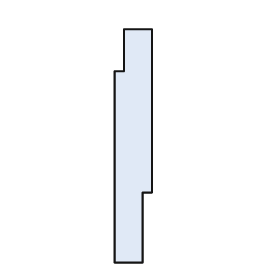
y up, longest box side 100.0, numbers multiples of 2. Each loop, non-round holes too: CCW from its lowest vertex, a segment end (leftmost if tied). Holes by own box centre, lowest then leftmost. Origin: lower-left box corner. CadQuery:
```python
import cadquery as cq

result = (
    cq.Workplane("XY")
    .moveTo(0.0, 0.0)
    .lineTo(12.0, 0.0)
    .lineTo(12.0, 30.0)
    .lineTo(16.0, 30.0)
    .lineTo(16.0, 100.0)
    .lineTo(4.0, 100.0)
    .lineTo(4.0, 82.0)
    .lineTo(0.0, 82.0)
    .close()
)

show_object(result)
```